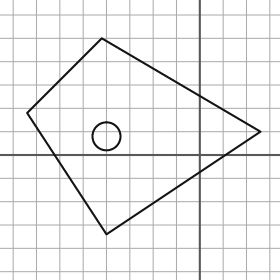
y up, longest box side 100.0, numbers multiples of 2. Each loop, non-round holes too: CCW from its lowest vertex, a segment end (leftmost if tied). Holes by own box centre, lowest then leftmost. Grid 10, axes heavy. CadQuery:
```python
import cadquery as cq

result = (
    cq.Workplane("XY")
    .moveTo(-40.0, -34.0)
    .lineTo(26.0, 10.0)
    .lineTo(-42.0, 50.0)
    .lineTo(-74.0, 18.0)
    .close()
    .moveTo(-40.0, 8.0)
    .circle(6.0)
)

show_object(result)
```